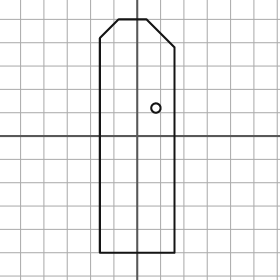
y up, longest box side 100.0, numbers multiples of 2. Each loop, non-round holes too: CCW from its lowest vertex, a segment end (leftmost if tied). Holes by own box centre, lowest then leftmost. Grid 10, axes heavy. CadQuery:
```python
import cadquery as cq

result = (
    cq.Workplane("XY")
    .moveTo(-16.0, -50.0)
    .lineTo(16.0, -50.0)
    .lineTo(16.0, 38.0)
    .lineTo(4.0, 50.0)
    .lineTo(-8.0, 50.0)
    .lineTo(-16.0, 42.0)
    .close()
    .moveTo(8.0, 12.0)
    .circle(2.0)
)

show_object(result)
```